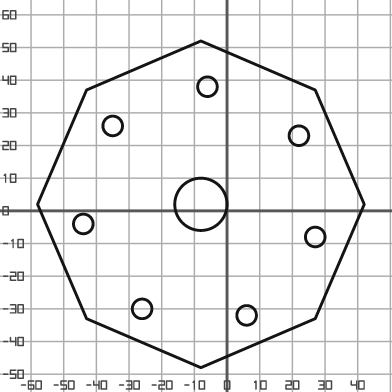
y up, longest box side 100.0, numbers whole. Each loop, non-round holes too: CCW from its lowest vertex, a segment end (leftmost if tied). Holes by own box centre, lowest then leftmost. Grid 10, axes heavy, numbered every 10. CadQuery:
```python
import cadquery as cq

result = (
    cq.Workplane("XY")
    .moveTo(-8.0, -48.0)
    .lineTo(27.0, -33.0)
    .lineTo(42.0, 2.0)
    .lineTo(27.0, 37.0)
    .lineTo(-8.0, 52.0)
    .lineTo(-43.0, 37.0)
    .lineTo(-58.0, 2.0)
    .lineTo(-43.0, -33.0)
    .close()
    .moveTo(6.0, -32.0)
    .circle(3.0)
    .moveTo(-26.0, -30.0)
    .circle(3.0)
    .moveTo(27.0, -8.0)
    .circle(3.0)
    .moveTo(-44.0, -4.0)
    .circle(3.0)
    .moveTo(-8.0, 2.0)
    .circle(8.0)
    .moveTo(22.0, 23.0)
    .circle(3.0)
    .moveTo(-35.0, 26.0)
    .circle(3.0)
    .moveTo(-6.0, 38.0)
    .circle(3.0)
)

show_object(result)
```